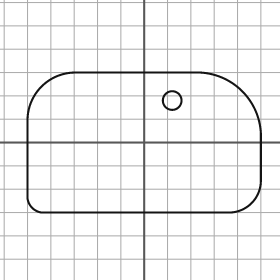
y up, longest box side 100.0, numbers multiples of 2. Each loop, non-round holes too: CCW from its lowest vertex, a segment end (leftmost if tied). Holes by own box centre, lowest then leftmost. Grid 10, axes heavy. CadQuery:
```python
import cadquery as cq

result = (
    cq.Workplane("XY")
    .moveTo(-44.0, -30.0)
    .lineTo(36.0, -30.0)
    .threePointArc((46.0, -26.0), (50.0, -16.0))
    .lineTo(50.0, 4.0)
    .threePointArc((42.0, 22.0), (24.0, 30.0))
    .lineTo(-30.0, 30.0)
    .threePointArc((-44.0, 24.0), (-50.0, 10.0))
    .lineTo(-50.0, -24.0)
    .threePointArc((-48.0, -28.0), (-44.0, -30.0))
    .close()
    .moveTo(12.0, 18.0)
    .circle(4.0)
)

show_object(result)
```